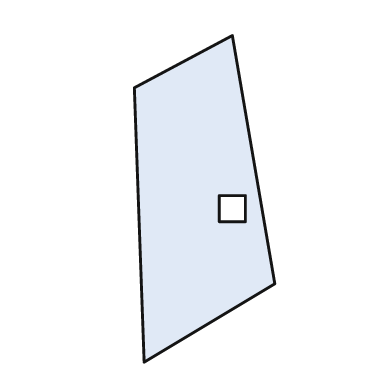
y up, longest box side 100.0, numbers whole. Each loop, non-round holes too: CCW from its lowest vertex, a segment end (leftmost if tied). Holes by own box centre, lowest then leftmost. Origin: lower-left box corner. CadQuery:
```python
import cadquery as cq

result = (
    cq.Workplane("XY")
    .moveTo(3.0, 0.0)
    .lineTo(43.0, 24.0)
    .lineTo(30.0, 100.0)
    .lineTo(0.0, 84.0)
    .close()
    .moveTo(26.0, 43.0)
    .lineTo(34.0, 43.0)
    .lineTo(34.0, 51.0)
    .lineTo(26.0, 51.0)
    .close()
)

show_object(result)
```